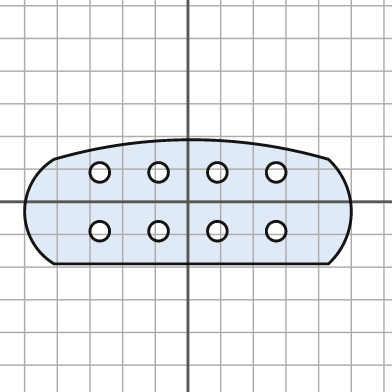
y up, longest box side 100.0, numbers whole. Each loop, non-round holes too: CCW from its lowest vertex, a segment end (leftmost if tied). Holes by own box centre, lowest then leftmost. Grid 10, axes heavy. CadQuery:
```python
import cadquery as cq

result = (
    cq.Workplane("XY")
    .moveTo(-41.0, -19.0)
    .lineTo(43.0, -19.0)
    .threePointArc((50.0, -3.0), (43.0, 13.0))
    .threePointArc((1.0, 19.0), (-41.0, 13.0))
    .threePointArc((-50.0, -3.0), (-41.0, -19.0))
    .close()
    .moveTo(-27.0, -9.0)
    .circle(3.0)
    .moveTo(-9.0, -9.0)
    .circle(3.0)
    .moveTo(9.0, -9.0)
    .circle(3.0)
    .moveTo(27.0, -9.0)
    .circle(3.0)
    .moveTo(-27.0, 9.0)
    .circle(3.0)
    .moveTo(-9.0, 9.0)
    .circle(3.0)
    .moveTo(9.0, 9.0)
    .circle(3.0)
    .moveTo(27.0, 9.0)
    .circle(3.0)
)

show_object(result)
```